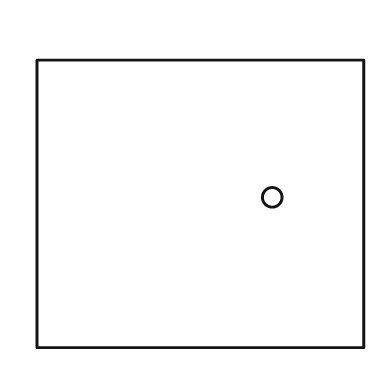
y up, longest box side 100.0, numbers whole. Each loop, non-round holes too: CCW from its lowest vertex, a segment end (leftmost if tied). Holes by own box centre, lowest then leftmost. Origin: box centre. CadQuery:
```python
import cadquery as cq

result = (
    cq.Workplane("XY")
    .moveTo(-50.0, -44.0)
    .lineTo(50.0, -44.0)
    .lineTo(50.0, 44.0)
    .lineTo(-50.0, 44.0)
    .close()
    .moveTo(22.0, 2.0)
    .circle(3.0)
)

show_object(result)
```